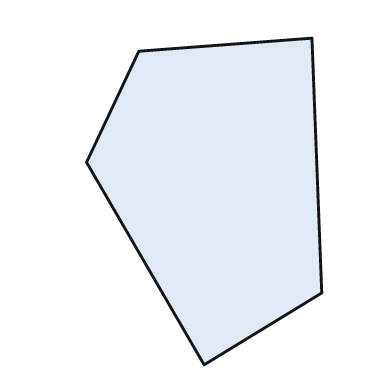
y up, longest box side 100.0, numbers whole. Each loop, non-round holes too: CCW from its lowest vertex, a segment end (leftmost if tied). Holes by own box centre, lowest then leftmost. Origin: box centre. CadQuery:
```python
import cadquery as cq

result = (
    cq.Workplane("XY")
    .moveTo(0.0, -50.0)
    .lineTo(36.0, -28.0)
    .lineTo(33.0, 50.0)
    .lineTo(-20.0, 46.0)
    .lineTo(-36.0, 12.0)
    .close()
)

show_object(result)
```